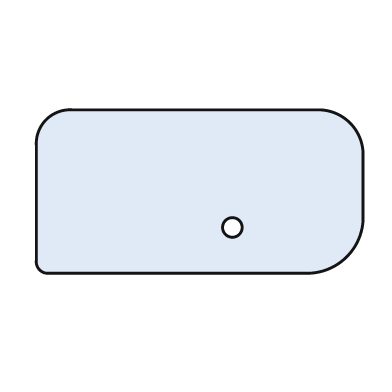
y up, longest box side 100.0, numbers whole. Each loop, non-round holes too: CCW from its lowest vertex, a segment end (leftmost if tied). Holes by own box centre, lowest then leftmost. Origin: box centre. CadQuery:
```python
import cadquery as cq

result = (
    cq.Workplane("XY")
    .moveTo(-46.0, -25.0)
    .lineTo(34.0, -25.0)
    .threePointArc((45.0, -20.0), (50.0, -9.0))
    .lineTo(50.0, 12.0)
    .threePointArc((46.0, 21.0), (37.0, 25.0))
    .lineTo(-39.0, 25.0)
    .threePointArc((-47.0, 22.0), (-50.0, 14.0))
    .lineTo(-50.0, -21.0)
    .threePointArc((-49.0, -24.0), (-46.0, -25.0))
    .close()
    .moveTo(10.0, -11.0)
    .circle(3.0)
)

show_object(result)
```